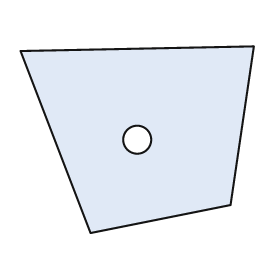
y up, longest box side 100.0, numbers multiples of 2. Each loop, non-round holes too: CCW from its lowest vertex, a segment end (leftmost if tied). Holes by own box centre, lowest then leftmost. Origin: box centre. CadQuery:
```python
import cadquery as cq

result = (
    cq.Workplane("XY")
    .moveTo(-20.0, -40.0)
    .lineTo(40.0, -28.0)
    .lineTo(50.0, 40.0)
    .lineTo(-50.0, 38.0)
    .close()
    .moveTo(0.0, 0.0)
    .circle(6.0)
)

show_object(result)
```